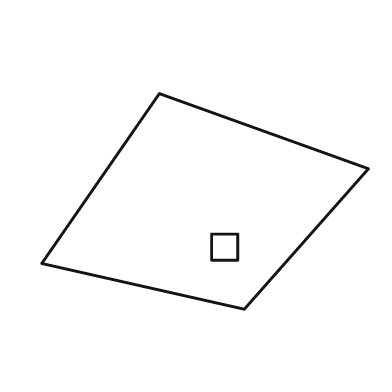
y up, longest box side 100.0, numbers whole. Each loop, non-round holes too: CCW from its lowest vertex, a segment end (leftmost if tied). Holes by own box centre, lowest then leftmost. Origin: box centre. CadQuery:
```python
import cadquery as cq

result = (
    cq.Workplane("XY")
    .moveTo(12.0, -33.0)
    .lineTo(50.0, 10.0)
    .lineTo(-14.0, 33.0)
    .lineTo(-50.0, -19.0)
    .close()
    .moveTo(2.0, -18.0)
    .lineTo(10.0, -18.0)
    .lineTo(10.0, -10.0)
    .lineTo(2.0, -10.0)
    .close()
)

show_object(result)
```